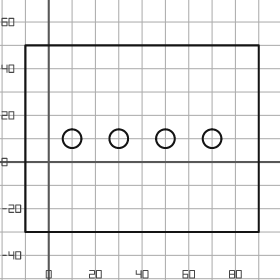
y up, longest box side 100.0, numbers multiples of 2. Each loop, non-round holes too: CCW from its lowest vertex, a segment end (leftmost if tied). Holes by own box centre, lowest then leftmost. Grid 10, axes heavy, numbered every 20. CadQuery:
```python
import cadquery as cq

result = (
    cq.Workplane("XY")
    .moveTo(-10.0, -30.0)
    .lineTo(90.0, -30.0)
    .lineTo(90.0, 50.0)
    .lineTo(-10.0, 50.0)
    .close()
    .moveTo(10.0, 10.0)
    .circle(4.0)
    .moveTo(30.0, 10.0)
    .circle(4.0)
    .moveTo(50.0, 10.0)
    .circle(4.0)
    .moveTo(70.0, 10.0)
    .circle(4.0)
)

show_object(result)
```